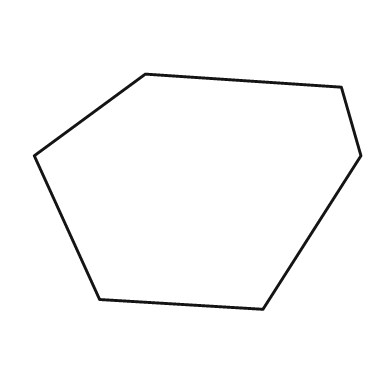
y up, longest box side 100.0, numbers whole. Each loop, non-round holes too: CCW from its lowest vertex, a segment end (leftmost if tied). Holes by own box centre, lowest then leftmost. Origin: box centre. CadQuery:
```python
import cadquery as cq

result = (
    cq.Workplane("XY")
    .moveTo(20.0, -36.0)
    .lineTo(50.0, 11.0)
    .lineTo(44.0, 32.0)
    .lineTo(-16.0, 36.0)
    .lineTo(-50.0, 11.0)
    .lineTo(-30.0, -33.0)
    .close()
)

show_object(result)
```